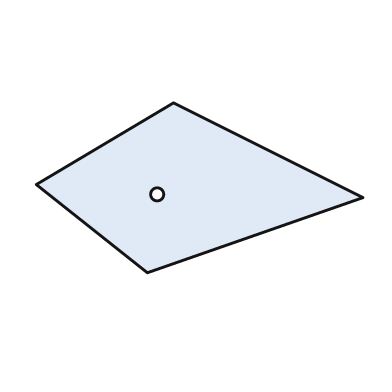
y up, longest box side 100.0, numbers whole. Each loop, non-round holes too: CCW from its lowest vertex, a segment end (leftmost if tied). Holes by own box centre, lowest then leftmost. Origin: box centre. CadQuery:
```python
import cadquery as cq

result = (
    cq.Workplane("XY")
    .moveTo(-16.0, -26.0)
    .lineTo(50.0, -3.0)
    .lineTo(-8.0, 26.0)
    .lineTo(-50.0, 1.0)
    .close()
    .moveTo(-13.0, -2.0)
    .circle(2.0)
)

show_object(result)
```